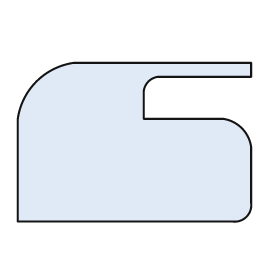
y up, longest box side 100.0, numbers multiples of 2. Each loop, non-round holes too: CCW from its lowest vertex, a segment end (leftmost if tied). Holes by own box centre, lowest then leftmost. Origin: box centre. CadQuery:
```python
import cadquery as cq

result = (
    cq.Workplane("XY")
    .moveTo(-50.0, -34.0)
    .lineTo(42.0, -34.0)
    .threePointArc((48.0, -32.0), (50.0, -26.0))
    .lineTo(50.0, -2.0)
    .threePointArc((46.0, 6.0), (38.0, 10.0))
    .lineTo(4.0, 10.0)
    .lineTo(4.0, 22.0)
    .threePointArc((6.0, 26.0), (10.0, 28.0))
    .lineTo(50.0, 28.0)
    .lineTo(50.0, 34.0)
    .lineTo(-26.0, 34.0)
    .threePointArc((-42.0, 26.0), (-50.0, 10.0))
    .close()
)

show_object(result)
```